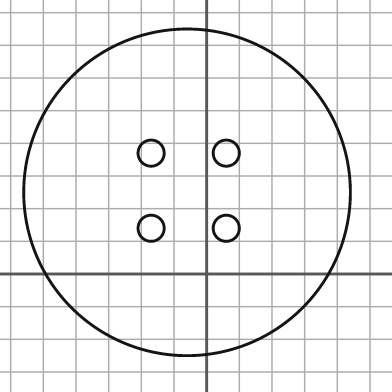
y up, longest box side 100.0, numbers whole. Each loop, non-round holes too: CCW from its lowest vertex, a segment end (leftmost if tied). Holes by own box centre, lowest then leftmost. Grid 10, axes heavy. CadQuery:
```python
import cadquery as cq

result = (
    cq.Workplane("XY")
    .moveTo(-6.0, 25.0)
    .circle(50.0)
    .moveTo(-17.0, 14.0)
    .circle(4.0)
    .moveTo(6.0, 14.0)
    .circle(4.0)
    .moveTo(-17.0, 37.0)
    .circle(4.0)
    .moveTo(6.0, 37.0)
    .circle(4.0)
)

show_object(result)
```